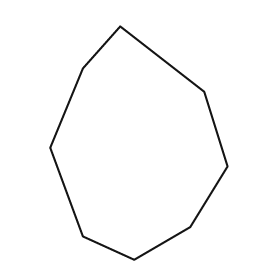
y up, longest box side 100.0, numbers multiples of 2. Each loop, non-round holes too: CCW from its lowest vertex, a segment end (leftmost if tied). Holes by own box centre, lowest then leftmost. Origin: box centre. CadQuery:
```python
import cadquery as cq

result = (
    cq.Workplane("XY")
    .moveTo(-2.0, -50.0)
    .lineTo(22.0, -36.0)
    .lineTo(38.0, -10.0)
    .lineTo(28.0, 22.0)
    .lineTo(-8.0, 50.0)
    .lineTo(-24.0, 32.0)
    .lineTo(-38.0, -2.0)
    .lineTo(-24.0, -40.0)
    .close()
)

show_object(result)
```